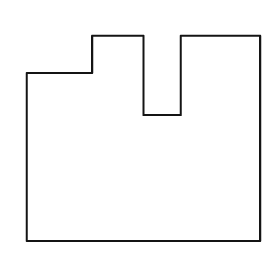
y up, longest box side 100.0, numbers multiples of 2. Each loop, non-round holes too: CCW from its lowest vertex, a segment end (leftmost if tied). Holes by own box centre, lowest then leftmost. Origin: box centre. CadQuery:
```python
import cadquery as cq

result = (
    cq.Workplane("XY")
    .moveTo(-50.0, -44.0)
    .lineTo(50.0, -44.0)
    .lineTo(50.0, 44.0)
    .lineTo(16.0, 44.0)
    .lineTo(16.0, 10.0)
    .lineTo(0.0, 10.0)
    .lineTo(0.0, 44.0)
    .lineTo(-22.0, 44.0)
    .lineTo(-22.0, 28.0)
    .lineTo(-50.0, 28.0)
    .close()
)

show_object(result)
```